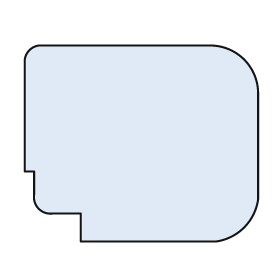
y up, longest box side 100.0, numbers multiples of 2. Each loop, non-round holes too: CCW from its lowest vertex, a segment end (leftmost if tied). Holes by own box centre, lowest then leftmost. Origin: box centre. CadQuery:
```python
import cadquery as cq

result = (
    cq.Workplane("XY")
    .moveTo(-26.0, -42.0)
    .lineTo(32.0, -42.0)
    .threePointArc((44.0, -36.0), (50.0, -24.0))
    .lineTo(50.0, 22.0)
    .threePointArc((44.0, 36.0), (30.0, 42.0))
    .lineTo(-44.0, 42.0)
    .threePointArc((-48.0, 40.0), (-50.0, 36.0))
    .lineTo(-50.0, -12.0)
    .lineTo(-46.0, -12.0)
    .lineTo(-46.0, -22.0)
    .threePointArc((-44.0, -28.0), (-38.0, -30.0))
    .lineTo(-26.0, -30.0)
    .close()
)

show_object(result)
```